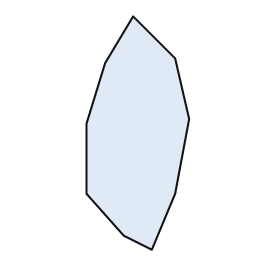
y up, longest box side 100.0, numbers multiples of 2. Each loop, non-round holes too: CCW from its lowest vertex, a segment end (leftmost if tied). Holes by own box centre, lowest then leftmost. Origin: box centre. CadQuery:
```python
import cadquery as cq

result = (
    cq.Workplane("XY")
    .moveTo(6.0, -50.0)
    .lineTo(16.0, -26.0)
    .lineTo(22.0, 6.0)
    .lineTo(16.0, 32.0)
    .lineTo(-2.0, 50.0)
    .lineTo(-14.0, 30.0)
    .lineTo(-22.0, 4.0)
    .lineTo(-22.0, -26.0)
    .lineTo(-6.0, -44.0)
    .close()
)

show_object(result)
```